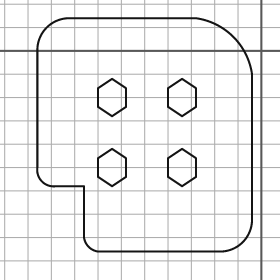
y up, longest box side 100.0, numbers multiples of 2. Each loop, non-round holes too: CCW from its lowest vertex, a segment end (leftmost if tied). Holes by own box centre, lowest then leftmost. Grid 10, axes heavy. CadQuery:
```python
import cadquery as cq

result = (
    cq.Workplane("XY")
    .moveTo(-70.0, -86.0)
    .lineTo(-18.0, -86.0)
    .threePointArc((-8.0, -82.0), (-4.0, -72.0))
    .lineTo(-4.0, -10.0)
    .threePointArc((-12.0, 6.0), (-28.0, 14.0))
    .lineTo(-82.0, 14.0)
    .threePointArc((-92.0, 10.0), (-96.0, 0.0))
    .lineTo(-96.0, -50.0)
    .threePointArc((-94.0, -56.0), (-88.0, -58.0))
    .lineTo(-76.0, -58.0)
    .lineTo(-76.0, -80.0)
    .threePointArc((-74.0, -84.0), (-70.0, -86.0))
    .close()
    .moveTo(-64.0, -58.0)
    .lineTo(-58.0, -54.0)
    .lineTo(-58.0, -46.0)
    .lineTo(-64.0, -42.0)
    .lineTo(-70.0, -46.0)
    .lineTo(-70.0, -54.0)
    .close()
    .moveTo(-34.0, -58.0)
    .lineTo(-28.0, -54.0)
    .lineTo(-28.0, -46.0)
    .lineTo(-34.0, -42.0)
    .lineTo(-40.0, -46.0)
    .lineTo(-40.0, -54.0)
    .close()
    .moveTo(-64.0, -28.0)
    .lineTo(-58.0, -24.0)
    .lineTo(-58.0, -16.0)
    .lineTo(-64.0, -12.0)
    .lineTo(-70.0, -16.0)
    .lineTo(-70.0, -24.0)
    .close()
    .moveTo(-34.0, -28.0)
    .lineTo(-28.0, -24.0)
    .lineTo(-28.0, -16.0)
    .lineTo(-34.0, -12.0)
    .lineTo(-40.0, -16.0)
    .lineTo(-40.0, -24.0)
    .close()
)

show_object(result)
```